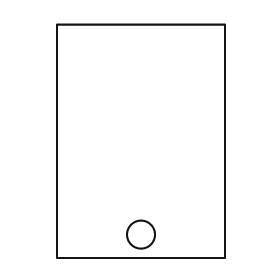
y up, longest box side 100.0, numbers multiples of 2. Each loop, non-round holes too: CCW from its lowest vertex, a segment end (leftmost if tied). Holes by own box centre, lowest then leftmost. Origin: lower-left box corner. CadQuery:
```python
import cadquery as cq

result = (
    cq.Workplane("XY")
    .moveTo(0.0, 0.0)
    .lineTo(72.0, 0.0)
    .lineTo(72.0, 100.0)
    .lineTo(0.0, 100.0)
    .close()
    .moveTo(36.0, 10.0)
    .circle(6.0)
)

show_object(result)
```